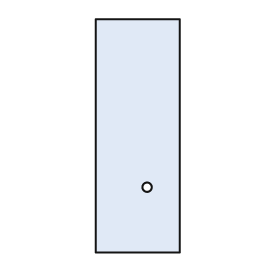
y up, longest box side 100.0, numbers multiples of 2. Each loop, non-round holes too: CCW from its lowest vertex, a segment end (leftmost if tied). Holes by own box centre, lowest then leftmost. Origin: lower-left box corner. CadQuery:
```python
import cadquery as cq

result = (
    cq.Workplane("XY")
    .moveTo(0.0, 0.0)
    .lineTo(36.0, 0.0)
    .lineTo(36.0, 100.0)
    .lineTo(0.0, 100.0)
    .close()
    .moveTo(22.0, 28.0)
    .circle(2.0)
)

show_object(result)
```